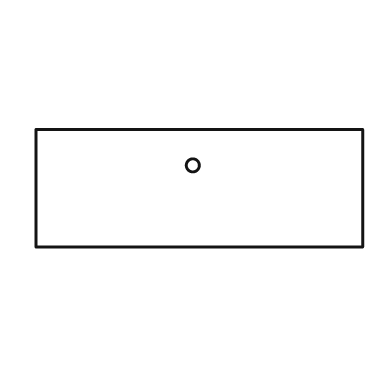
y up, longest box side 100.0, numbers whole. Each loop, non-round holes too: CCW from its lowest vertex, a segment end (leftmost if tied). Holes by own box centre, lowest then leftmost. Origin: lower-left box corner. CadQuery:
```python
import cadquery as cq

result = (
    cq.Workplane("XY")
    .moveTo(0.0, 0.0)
    .lineTo(100.0, 0.0)
    .lineTo(100.0, 36.0)
    .lineTo(0.0, 36.0)
    .close()
    .moveTo(48.0, 25.0)
    .circle(2.0)
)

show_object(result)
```